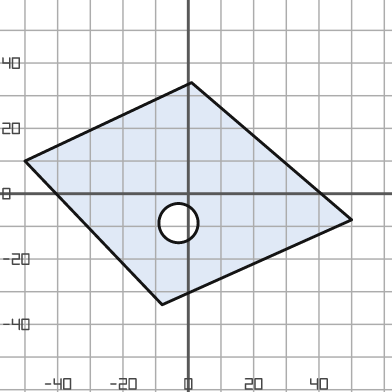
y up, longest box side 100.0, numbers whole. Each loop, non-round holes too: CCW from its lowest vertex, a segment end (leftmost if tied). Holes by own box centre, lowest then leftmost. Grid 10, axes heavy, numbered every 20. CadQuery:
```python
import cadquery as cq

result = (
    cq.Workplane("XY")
    .moveTo(-8.0, -34.0)
    .lineTo(50.0, -8.0)
    .lineTo(1.0, 34.0)
    .lineTo(-50.0, 10.0)
    .close()
    .moveTo(-3.0, -9.0)
    .circle(6.0)
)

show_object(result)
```